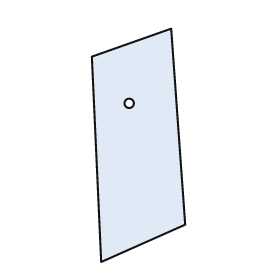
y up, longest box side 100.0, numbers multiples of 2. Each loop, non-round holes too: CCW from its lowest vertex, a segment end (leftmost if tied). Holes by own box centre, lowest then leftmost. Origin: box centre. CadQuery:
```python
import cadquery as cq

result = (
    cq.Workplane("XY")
    .moveTo(-16.0, -50.0)
    .lineTo(20.0, -34.0)
    .lineTo(14.0, 50.0)
    .lineTo(-20.0, 38.0)
    .close()
    .moveTo(-4.0, 18.0)
    .circle(2.0)
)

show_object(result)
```